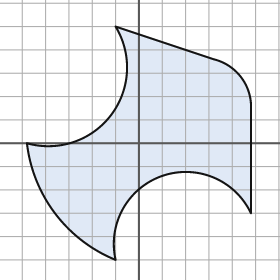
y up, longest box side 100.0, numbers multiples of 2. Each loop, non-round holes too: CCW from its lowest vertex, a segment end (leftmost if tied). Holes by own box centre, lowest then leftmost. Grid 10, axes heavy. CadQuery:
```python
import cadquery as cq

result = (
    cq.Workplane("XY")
    .moveTo(-10.0, -50.0)
    .threePointArc((10.0, -14.0), (48.0, -30.0))
    .lineTo(48.0, 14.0)
    .threePointArc((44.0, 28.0), (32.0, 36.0))
    .lineTo(-10.0, 50.0)
    .threePointArc((-12.0, 12.0), (-48.0, 0.0))
    .threePointArc((-36.0, -30.0), (-10.0, -50.0))
    .close()
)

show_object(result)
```